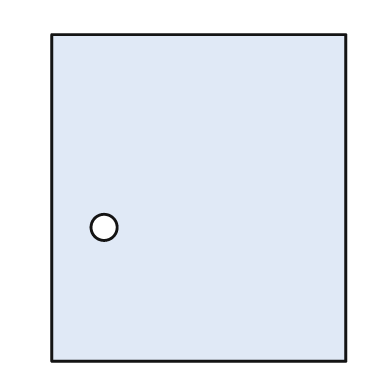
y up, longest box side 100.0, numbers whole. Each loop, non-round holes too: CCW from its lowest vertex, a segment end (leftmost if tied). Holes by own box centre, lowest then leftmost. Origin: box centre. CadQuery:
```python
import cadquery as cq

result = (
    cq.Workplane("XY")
    .moveTo(-45.0, -50.0)
    .lineTo(45.0, -50.0)
    .lineTo(45.0, 50.0)
    .lineTo(-45.0, 50.0)
    .close()
    .moveTo(-29.0, -9.0)
    .circle(4.0)
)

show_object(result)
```